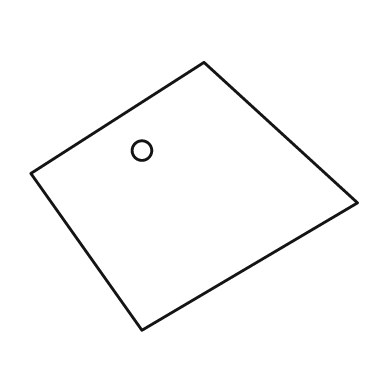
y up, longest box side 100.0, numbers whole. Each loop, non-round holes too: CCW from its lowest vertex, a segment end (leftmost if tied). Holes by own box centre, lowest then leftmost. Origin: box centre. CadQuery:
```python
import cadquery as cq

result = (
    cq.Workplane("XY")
    .moveTo(-16.0, -41.0)
    .lineTo(50.0, -2.0)
    .lineTo(3.0, 41.0)
    .lineTo(-50.0, 7.0)
    .close()
    .moveTo(-16.0, 14.0)
    .circle(3.0)
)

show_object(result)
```